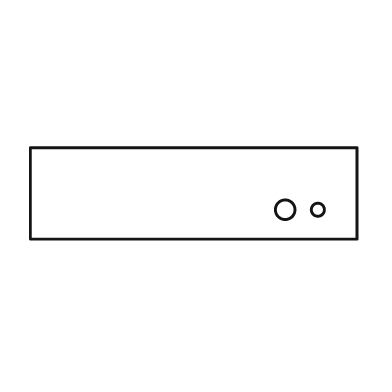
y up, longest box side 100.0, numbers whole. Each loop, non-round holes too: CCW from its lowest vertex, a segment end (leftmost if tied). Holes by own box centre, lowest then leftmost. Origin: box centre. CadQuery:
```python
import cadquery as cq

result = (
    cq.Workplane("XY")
    .moveTo(-50.0, -14.0)
    .lineTo(50.0, -14.0)
    .lineTo(50.0, 14.0)
    .lineTo(-50.0, 14.0)
    .close()
    .moveTo(28.0, -5.0)
    .circle(3.0)
    .moveTo(38.0, -5.0)
    .circle(2.0)
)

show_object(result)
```